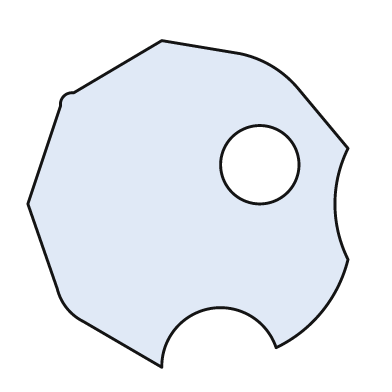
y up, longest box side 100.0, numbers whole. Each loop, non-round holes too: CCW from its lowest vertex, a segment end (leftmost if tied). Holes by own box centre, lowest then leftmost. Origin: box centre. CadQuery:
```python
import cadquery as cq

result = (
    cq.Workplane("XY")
    .moveTo(-8.0, -50.0)
    .threePointArc((7.0, -32.0), (27.0, -44.0))
    .threePointArc((41.0, -33.0), (49.0, -17.0))
    .threePointArc((45.0, 0.0), (49.0, 17.0))
    .lineTo(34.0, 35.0)
    .threePointArc((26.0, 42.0), (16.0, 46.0))
    .lineTo(-8.0, 50.0)
    .lineTo(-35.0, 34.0)
    .threePointArc((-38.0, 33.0), (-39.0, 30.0))
    .lineTo(-49.0, 0.0)
    .lineTo(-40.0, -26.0)
    .threePointArc((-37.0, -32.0), (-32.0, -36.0))
    .close()
    .moveTo(22.0, 12.0)
    .circle(12.0)
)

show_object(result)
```